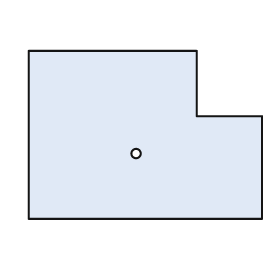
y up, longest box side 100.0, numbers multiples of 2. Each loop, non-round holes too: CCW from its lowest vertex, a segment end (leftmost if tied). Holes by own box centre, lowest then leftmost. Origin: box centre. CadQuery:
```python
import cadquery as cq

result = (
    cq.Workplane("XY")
    .moveTo(-50.0, -36.0)
    .lineTo(50.0, -36.0)
    .lineTo(50.0, 8.0)
    .lineTo(22.0, 8.0)
    .lineTo(22.0, 36.0)
    .lineTo(-50.0, 36.0)
    .close()
    .moveTo(-4.0, -8.0)
    .circle(2.0)
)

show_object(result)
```